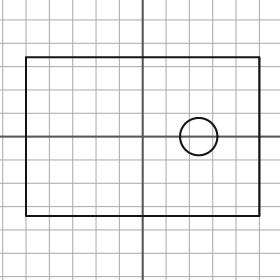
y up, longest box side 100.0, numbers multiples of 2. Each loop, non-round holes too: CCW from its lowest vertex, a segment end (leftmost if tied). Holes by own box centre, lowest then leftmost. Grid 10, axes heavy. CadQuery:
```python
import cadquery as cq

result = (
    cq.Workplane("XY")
    .moveTo(-50.0, -34.0)
    .lineTo(50.0, -34.0)
    .lineTo(50.0, 34.0)
    .lineTo(-50.0, 34.0)
    .close()
    .moveTo(24.0, 0.0)
    .circle(8.0)
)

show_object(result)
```